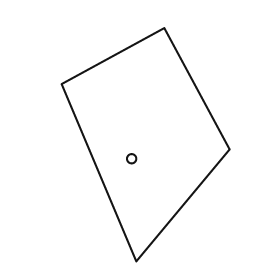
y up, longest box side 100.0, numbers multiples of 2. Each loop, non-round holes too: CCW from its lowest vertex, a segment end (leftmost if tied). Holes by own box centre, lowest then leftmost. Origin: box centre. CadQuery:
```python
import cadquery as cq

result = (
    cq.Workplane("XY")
    .moveTo(-4.0, -50.0)
    .lineTo(36.0, -2.0)
    .lineTo(8.0, 50.0)
    .lineTo(-36.0, 26.0)
    .close()
    .moveTo(-6.0, -6.0)
    .circle(2.0)
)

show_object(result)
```